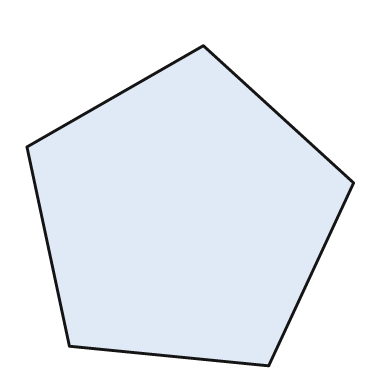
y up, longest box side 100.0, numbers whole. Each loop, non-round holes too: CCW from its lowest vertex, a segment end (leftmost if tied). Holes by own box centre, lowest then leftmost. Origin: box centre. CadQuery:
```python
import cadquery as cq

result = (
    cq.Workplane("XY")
    .moveTo(24.0, -49.0)
    .lineTo(50.0, 7.0)
    .lineTo(4.0, 49.0)
    .lineTo(-50.0, 18.0)
    .lineTo(-37.0, -43.0)
    .close()
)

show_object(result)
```